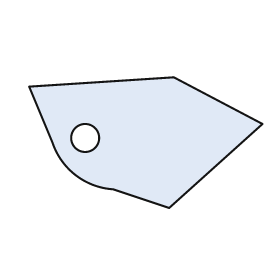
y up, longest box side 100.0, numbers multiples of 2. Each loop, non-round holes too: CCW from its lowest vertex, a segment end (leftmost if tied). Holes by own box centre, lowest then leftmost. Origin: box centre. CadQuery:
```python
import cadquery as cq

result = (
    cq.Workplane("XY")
    .moveTo(10.0, -28.0)
    .lineTo(50.0, 8.0)
    .lineTo(12.0, 28.0)
    .lineTo(-50.0, 24.0)
    .lineTo(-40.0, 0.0)
    .threePointArc((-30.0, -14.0), (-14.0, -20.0))
    .close()
    .moveTo(-26.0, 2.0)
    .circle(6.0)
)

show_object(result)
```